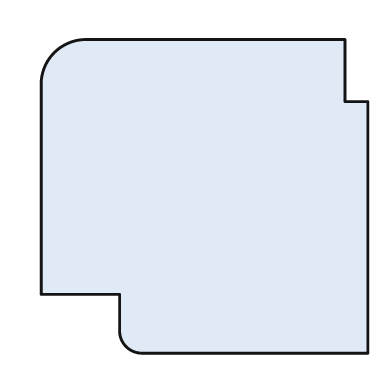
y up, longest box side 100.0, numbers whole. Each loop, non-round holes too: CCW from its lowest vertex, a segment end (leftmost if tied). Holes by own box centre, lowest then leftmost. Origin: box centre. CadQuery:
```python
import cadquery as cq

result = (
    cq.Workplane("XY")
    .moveTo(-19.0, -48.0)
    .lineTo(50.0, -48.0)
    .lineTo(50.0, 29.0)
    .lineTo(43.0, 29.0)
    .lineTo(43.0, 48.0)
    .lineTo(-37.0, 48.0)
    .threePointArc((-46.0, 44.0), (-50.0, 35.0))
    .lineTo(-50.0, -30.0)
    .lineTo(-26.0, -30.0)
    .lineTo(-26.0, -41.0)
    .threePointArc((-24.0, -46.0), (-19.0, -48.0))
    .close()
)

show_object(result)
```